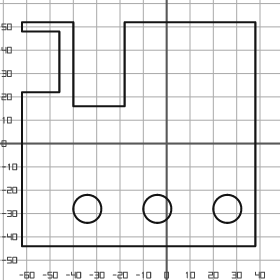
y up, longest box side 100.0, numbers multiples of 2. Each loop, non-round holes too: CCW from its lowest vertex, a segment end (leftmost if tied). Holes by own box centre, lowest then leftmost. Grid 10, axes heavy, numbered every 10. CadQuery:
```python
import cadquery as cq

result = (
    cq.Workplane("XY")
    .moveTo(-62.0, -44.0)
    .lineTo(38.0, -44.0)
    .lineTo(38.0, 52.0)
    .lineTo(-18.0, 52.0)
    .lineTo(-18.0, 16.0)
    .lineTo(-40.0, 16.0)
    .lineTo(-40.0, 52.0)
    .lineTo(-62.0, 52.0)
    .lineTo(-62.0, 48.0)
    .lineTo(-46.0, 48.0)
    .lineTo(-46.0, 22.0)
    .lineTo(-62.0, 22.0)
    .close()
    .moveTo(-34.0, -28.0)
    .circle(6.0)
    .moveTo(-4.0, -28.0)
    .circle(6.0)
    .moveTo(26.0, -28.0)
    .circle(6.0)
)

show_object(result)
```